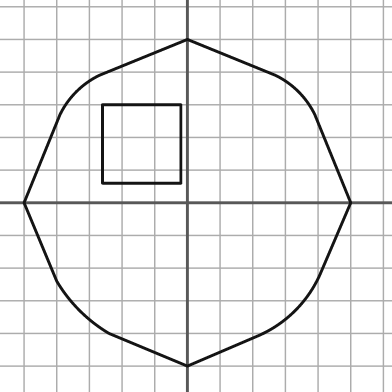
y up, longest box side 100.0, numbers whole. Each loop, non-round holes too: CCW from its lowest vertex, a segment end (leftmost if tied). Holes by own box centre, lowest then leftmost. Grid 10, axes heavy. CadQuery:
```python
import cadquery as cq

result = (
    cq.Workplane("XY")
    .moveTo(0.0, -50.0)
    .lineTo(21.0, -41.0)
    .threePointArc((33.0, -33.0), (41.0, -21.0))
    .lineTo(50.0, 0.0)
    .lineTo(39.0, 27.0)
    .threePointArc((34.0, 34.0), (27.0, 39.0))
    .lineTo(0.0, 50.0)
    .lineTo(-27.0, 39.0)
    .threePointArc((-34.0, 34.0), (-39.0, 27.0))
    .lineTo(-50.0, 0.0)
    .lineTo(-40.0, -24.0)
    .threePointArc((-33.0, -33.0), (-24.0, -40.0))
    .close()
    .moveTo(-26.0, 6.0)
    .lineTo(-2.0, 6.0)
    .lineTo(-2.0, 30.0)
    .lineTo(-26.0, 30.0)
    .close()
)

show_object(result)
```